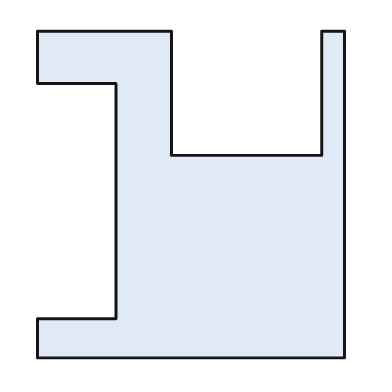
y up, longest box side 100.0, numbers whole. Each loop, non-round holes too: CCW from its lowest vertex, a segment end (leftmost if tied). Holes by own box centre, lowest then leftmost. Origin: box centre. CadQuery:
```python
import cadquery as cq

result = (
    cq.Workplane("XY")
    .moveTo(-47.0, -50.0)
    .lineTo(47.0, -50.0)
    .lineTo(47.0, 50.0)
    .lineTo(40.0, 50.0)
    .lineTo(40.0, 12.0)
    .lineTo(-6.0, 12.0)
    .lineTo(-6.0, 50.0)
    .lineTo(-47.0, 50.0)
    .lineTo(-47.0, 34.0)
    .lineTo(-23.0, 34.0)
    .lineTo(-23.0, -38.0)
    .lineTo(-47.0, -38.0)
    .close()
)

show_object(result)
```